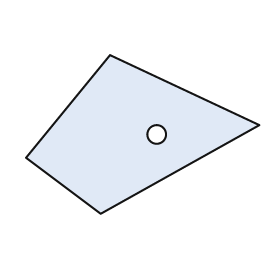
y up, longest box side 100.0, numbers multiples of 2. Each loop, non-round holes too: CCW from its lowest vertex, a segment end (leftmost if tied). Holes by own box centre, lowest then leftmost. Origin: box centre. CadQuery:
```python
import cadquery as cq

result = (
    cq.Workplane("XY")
    .moveTo(-18.0, -34.0)
    .lineTo(50.0, 4.0)
    .lineTo(-14.0, 34.0)
    .lineTo(-50.0, -10.0)
    .close()
    .moveTo(6.0, 0.0)
    .circle(4.0)
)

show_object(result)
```